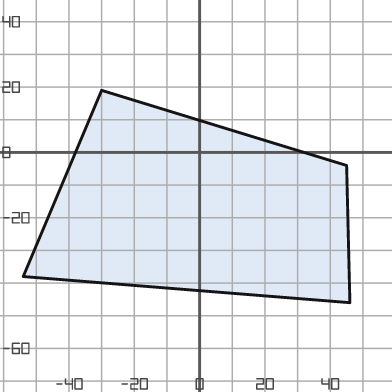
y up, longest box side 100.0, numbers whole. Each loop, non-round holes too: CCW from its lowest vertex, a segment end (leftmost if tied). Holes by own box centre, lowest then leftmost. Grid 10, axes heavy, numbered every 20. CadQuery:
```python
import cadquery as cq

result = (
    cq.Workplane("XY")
    .moveTo(46.0, -46.0)
    .lineTo(45.0, -4.0)
    .lineTo(-30.0, 19.0)
    .lineTo(-54.0, -38.0)
    .close()
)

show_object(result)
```